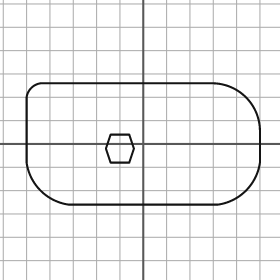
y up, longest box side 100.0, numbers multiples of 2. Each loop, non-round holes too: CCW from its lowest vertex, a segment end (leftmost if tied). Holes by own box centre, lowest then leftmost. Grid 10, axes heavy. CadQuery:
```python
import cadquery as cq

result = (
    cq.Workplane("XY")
    .moveTo(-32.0, -26.0)
    .lineTo(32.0, -26.0)
    .threePointArc((44.0, -20.0), (50.0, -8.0))
    .lineTo(50.0, 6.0)
    .threePointArc((44.0, 20.0), (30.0, 26.0))
    .lineTo(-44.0, 26.0)
    .threePointArc((-48.0, 24.0), (-50.0, 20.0))
    .lineTo(-50.0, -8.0)
    .threePointArc((-44.0, -20.0), (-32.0, -26.0))
    .close()
    .moveTo(-14.0, -8.0)
    .lineTo(-6.0, -8.0)
    .lineTo(-4.0, -2.0)
    .lineTo(-6.0, 4.0)
    .lineTo(-14.0, 4.0)
    .lineTo(-16.0, -2.0)
    .close()
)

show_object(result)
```